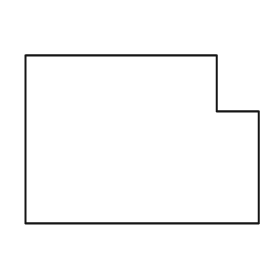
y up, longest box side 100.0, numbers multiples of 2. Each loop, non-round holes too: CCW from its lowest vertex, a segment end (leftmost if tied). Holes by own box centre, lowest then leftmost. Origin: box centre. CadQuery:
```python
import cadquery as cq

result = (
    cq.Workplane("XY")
    .moveTo(-50.0, -36.0)
    .lineTo(50.0, -36.0)
    .lineTo(50.0, 12.0)
    .lineTo(32.0, 12.0)
    .lineTo(32.0, 36.0)
    .lineTo(-50.0, 36.0)
    .close()
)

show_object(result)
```